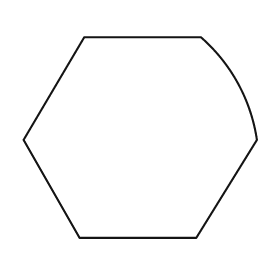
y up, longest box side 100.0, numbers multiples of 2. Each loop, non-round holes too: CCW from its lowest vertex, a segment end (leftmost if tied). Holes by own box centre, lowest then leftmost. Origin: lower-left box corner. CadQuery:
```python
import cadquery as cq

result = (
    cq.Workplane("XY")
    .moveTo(24.0, 0.0)
    .lineTo(74.0, 0.0)
    .lineTo(100.0, 42.0)
    .threePointArc((92.0, 66.0), (76.0, 86.0))
    .lineTo(26.0, 86.0)
    .lineTo(0.0, 42.0)
    .close()
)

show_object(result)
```